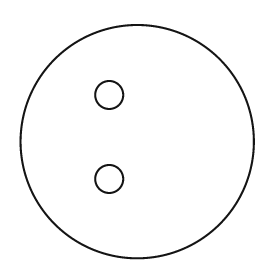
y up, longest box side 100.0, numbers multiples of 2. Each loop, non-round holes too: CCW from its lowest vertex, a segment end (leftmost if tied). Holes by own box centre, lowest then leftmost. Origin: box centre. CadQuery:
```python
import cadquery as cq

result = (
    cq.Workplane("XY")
    .moveTo(0.0, 0.0)
    .circle(50.0)
    .moveTo(-12.0, -16.0)
    .circle(6.0)
    .moveTo(-12.0, 20.0)
    .circle(6.0)
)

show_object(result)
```